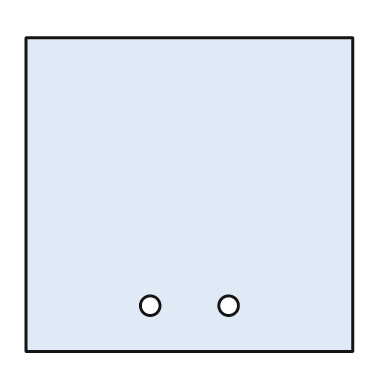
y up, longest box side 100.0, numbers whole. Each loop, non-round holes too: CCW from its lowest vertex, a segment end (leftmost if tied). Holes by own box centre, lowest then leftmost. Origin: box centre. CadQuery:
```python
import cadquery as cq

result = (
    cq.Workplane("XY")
    .moveTo(-50.0, -48.0)
    .lineTo(50.0, -48.0)
    .lineTo(50.0, 48.0)
    .lineTo(-50.0, 48.0)
    .close()
    .moveTo(-12.0, -34.0)
    .circle(3.0)
    .moveTo(12.0, -34.0)
    .circle(3.0)
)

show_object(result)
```